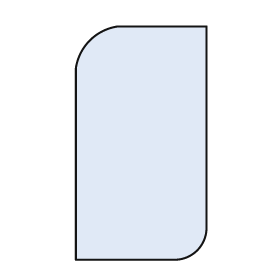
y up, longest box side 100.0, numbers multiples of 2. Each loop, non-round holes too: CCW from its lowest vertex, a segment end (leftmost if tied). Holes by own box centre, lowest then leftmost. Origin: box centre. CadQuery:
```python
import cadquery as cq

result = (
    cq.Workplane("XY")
    .moveTo(-28.0, -50.0)
    .lineTo(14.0, -50.0)
    .threePointArc((24.0, -46.0), (28.0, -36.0))
    .lineTo(28.0, 50.0)
    .lineTo(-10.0, 50.0)
    .threePointArc((-22.0, 44.0), (-28.0, 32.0))
    .close()
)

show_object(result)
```